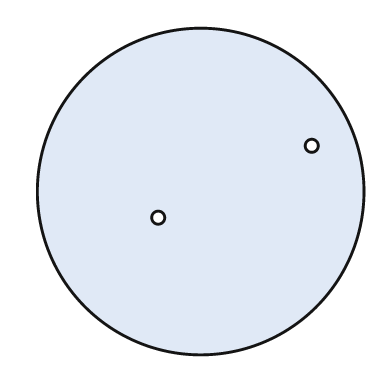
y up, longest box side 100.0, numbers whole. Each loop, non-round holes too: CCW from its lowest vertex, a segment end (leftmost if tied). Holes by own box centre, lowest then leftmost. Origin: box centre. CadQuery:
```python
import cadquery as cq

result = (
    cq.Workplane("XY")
    .moveTo(0.0, 0.0)
    .circle(50.0)
    .moveTo(-13.0, -8.0)
    .circle(2.0)
    .moveTo(34.0, 14.0)
    .circle(2.0)
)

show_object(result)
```